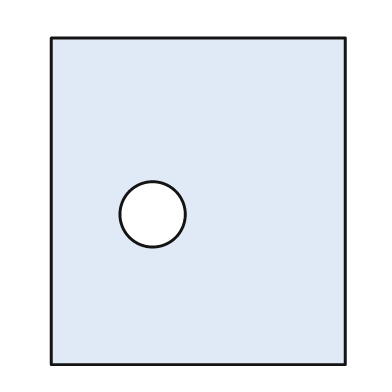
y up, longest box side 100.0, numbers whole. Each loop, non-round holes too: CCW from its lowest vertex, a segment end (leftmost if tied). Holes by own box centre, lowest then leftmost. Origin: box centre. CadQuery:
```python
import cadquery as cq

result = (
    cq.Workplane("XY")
    .moveTo(-45.0, -50.0)
    .lineTo(45.0, -50.0)
    .lineTo(45.0, 50.0)
    .lineTo(-45.0, 50.0)
    .close()
    .moveTo(-14.0, -4.0)
    .circle(10.0)
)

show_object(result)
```